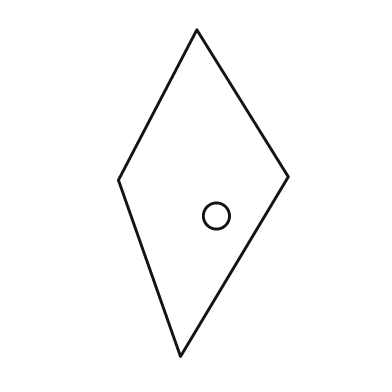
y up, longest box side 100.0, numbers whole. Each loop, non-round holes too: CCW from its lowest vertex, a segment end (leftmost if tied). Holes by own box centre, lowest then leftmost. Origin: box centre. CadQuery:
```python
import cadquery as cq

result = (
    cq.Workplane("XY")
    .moveTo(-7.0, -50.0)
    .lineTo(26.0, 5.0)
    .lineTo(-2.0, 50.0)
    .lineTo(-26.0, 4.0)
    .close()
    .moveTo(4.0, -7.0)
    .circle(4.0)
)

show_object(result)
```